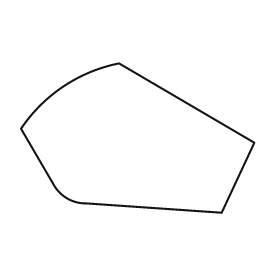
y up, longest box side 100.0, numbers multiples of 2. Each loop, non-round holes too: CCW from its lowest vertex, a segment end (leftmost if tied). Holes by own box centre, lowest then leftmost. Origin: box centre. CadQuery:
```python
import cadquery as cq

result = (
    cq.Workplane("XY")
    .moveTo(36.0, -32.0)
    .lineTo(50.0, -2.0)
    .lineTo(-8.0, 32.0)
    .threePointArc((-32.0, 22.0), (-50.0, 4.0))
    .lineTo(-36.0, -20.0)
    .threePointArc((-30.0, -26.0), (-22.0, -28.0))
    .close()
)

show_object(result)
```